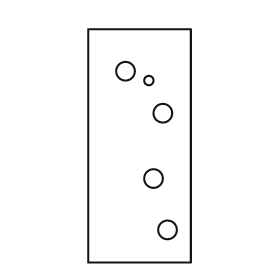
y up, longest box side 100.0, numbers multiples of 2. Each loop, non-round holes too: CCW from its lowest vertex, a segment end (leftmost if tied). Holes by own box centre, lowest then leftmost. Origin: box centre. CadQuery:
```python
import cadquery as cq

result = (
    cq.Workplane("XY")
    .moveTo(-22.0, -50.0)
    .lineTo(22.0, -50.0)
    .lineTo(22.0, 50.0)
    .lineTo(-22.0, 50.0)
    .close()
    .moveTo(12.0, -36.0)
    .circle(4.0)
    .moveTo(6.0, -14.0)
    .circle(4.0)
    .moveTo(10.0, 14.0)
    .circle(4.0)
    .moveTo(4.0, 28.0)
    .circle(2.0)
    .moveTo(-6.0, 32.0)
    .circle(4.0)
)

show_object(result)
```